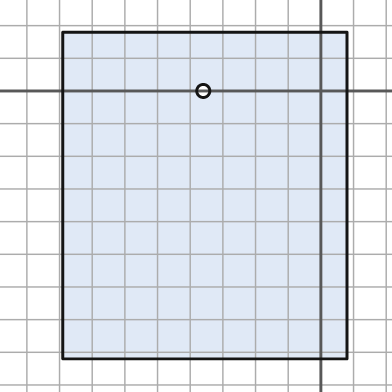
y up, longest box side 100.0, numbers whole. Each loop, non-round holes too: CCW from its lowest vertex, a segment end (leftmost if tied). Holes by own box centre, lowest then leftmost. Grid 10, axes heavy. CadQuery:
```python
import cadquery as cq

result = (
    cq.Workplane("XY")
    .moveTo(-79.0, -82.0)
    .lineTo(8.0, -82.0)
    .lineTo(8.0, 18.0)
    .lineTo(-79.0, 18.0)
    .close()
    .moveTo(-36.0, 0.0)
    .circle(2.0)
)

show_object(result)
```